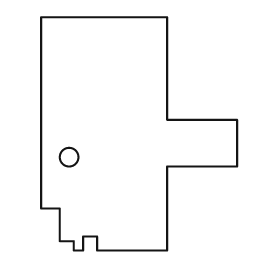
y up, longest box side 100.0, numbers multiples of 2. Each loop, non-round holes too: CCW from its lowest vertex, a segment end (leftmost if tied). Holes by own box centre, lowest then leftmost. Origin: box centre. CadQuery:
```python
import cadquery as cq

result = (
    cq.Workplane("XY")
    .moveTo(-28.0, -50.0)
    .lineTo(-24.0, -50.0)
    .lineTo(-24.0, -44.0)
    .lineTo(-18.0, -44.0)
    .lineTo(-18.0, -50.0)
    .lineTo(12.0, -50.0)
    .lineTo(12.0, -14.0)
    .lineTo(42.0, -14.0)
    .lineTo(42.0, 6.0)
    .lineTo(12.0, 6.0)
    .lineTo(12.0, 50.0)
    .lineTo(-42.0, 50.0)
    .lineTo(-42.0, -32.0)
    .lineTo(-34.0, -32.0)
    .lineTo(-34.0, -46.0)
    .lineTo(-28.0, -46.0)
    .close()
    .moveTo(-30.0, -10.0)
    .circle(4.0)
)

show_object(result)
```